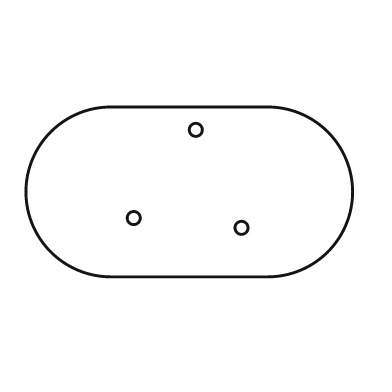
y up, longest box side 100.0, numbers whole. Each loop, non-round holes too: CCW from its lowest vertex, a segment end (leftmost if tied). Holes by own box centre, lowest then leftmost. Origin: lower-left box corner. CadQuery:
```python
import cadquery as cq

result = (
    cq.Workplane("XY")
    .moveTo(26.0, 0.0)
    .lineTo(74.0, 0.0)
    .threePointArc((100.0, 26.0), (74.0, 52.0))
    .lineTo(26.0, 52.0)
    .threePointArc((0.0, 26.0), (26.0, 0.0))
    .close()
    .moveTo(66.0, 15.0)
    .circle(2.0)
    .moveTo(33.0, 18.0)
    .circle(2.0)
    .moveTo(52.0, 45.0)
    .circle(2.0)
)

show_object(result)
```